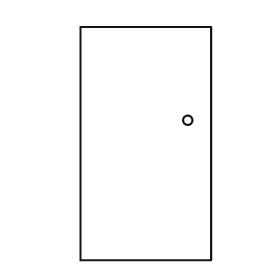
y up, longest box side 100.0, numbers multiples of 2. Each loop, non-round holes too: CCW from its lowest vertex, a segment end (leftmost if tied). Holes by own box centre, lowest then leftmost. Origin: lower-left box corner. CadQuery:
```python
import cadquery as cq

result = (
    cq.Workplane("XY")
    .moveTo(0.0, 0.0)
    .lineTo(56.0, 0.0)
    .lineTo(56.0, 100.0)
    .lineTo(0.0, 100.0)
    .close()
    .moveTo(46.0, 60.0)
    .circle(2.0)
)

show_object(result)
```